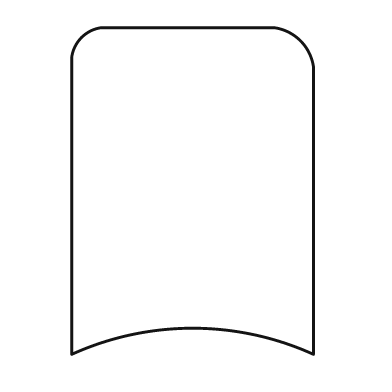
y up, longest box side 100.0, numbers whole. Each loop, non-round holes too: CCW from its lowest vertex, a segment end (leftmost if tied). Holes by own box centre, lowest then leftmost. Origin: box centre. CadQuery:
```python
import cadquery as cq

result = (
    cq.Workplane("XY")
    .moveTo(-37.0, -50.0)
    .threePointArc((0.0, -42.0), (37.0, -50.0))
    .lineTo(37.0, 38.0)
    .threePointArc((33.0, 46.0), (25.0, 50.0))
    .lineTo(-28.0, 50.0)
    .threePointArc((-34.0, 47.0), (-37.0, 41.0))
    .close()
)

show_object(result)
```